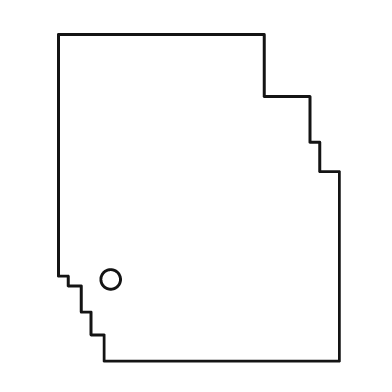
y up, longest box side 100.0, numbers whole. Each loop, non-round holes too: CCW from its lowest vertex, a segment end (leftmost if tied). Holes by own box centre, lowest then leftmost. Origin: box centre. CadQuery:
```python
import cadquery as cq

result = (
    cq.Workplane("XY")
    .moveTo(-29.0, -50.0)
    .lineTo(43.0, -50.0)
    .lineTo(43.0, 8.0)
    .lineTo(37.0, 8.0)
    .lineTo(37.0, 17.0)
    .lineTo(34.0, 17.0)
    .lineTo(34.0, 31.0)
    .lineTo(20.0, 31.0)
    .lineTo(20.0, 50.0)
    .lineTo(-43.0, 50.0)
    .lineTo(-43.0, -24.0)
    .lineTo(-40.0, -24.0)
    .lineTo(-40.0, -27.0)
    .lineTo(-36.0, -27.0)
    .lineTo(-36.0, -35.0)
    .lineTo(-33.0, -35.0)
    .lineTo(-33.0, -42.0)
    .lineTo(-29.0, -42.0)
    .close()
    .moveTo(-27.0, -25.0)
    .circle(3.0)
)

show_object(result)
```